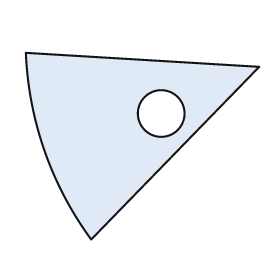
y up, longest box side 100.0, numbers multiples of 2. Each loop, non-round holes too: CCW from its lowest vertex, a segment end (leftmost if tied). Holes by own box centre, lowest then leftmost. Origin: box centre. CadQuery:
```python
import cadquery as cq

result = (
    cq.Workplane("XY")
    .moveTo(-22.0, -40.0)
    .lineTo(50.0, 34.0)
    .lineTo(-50.0, 40.0)
    .threePointArc((-42.0, -2.0), (-22.0, -40.0))
    .close()
    .moveTo(8.0, 14.0)
    .circle(10.0)
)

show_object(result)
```